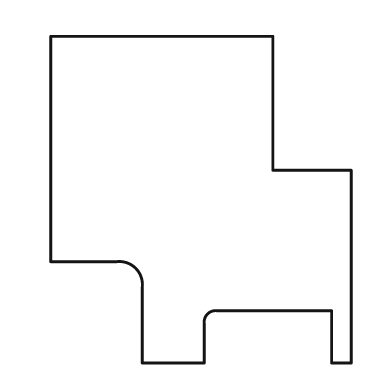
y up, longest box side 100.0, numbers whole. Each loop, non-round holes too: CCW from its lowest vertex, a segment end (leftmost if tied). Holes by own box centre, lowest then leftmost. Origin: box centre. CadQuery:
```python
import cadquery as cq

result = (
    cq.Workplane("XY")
    .moveTo(-18.0, -50.0)
    .lineTo(1.0, -50.0)
    .lineTo(1.0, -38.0)
    .threePointArc((2.0, -35.0), (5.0, -34.0))
    .lineTo(40.0, -34.0)
    .lineTo(40.0, -50.0)
    .lineTo(46.0, -50.0)
    .lineTo(46.0, 9.0)
    .lineTo(22.0, 9.0)
    .lineTo(22.0, 50.0)
    .lineTo(-46.0, 50.0)
    .lineTo(-46.0, -19.0)
    .lineTo(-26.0, -19.0)
    .threePointArc((-20.0, -21.0), (-18.0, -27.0))
    .close()
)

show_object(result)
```